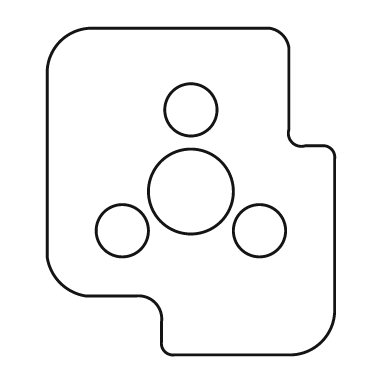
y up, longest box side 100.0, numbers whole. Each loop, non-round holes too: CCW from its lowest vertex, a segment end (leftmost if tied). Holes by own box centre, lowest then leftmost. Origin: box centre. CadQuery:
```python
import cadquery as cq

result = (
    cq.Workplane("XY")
    .moveTo(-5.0, -50.0)
    .lineTo(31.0, -50.0)
    .threePointArc((40.0, -46.0), (44.0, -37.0))
    .lineTo(44.0, 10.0)
    .threePointArc((43.0, 13.0), (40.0, 14.0))
    .lineTo(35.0, 14.0)
    .threePointArc((31.0, 15.0), (30.0, 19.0))
    .lineTo(30.0, 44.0)
    .threePointArc((28.0, 48.0), (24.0, 50.0))
    .lineTo(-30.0, 50.0)
    .threePointArc((-40.0, 46.0), (-44.0, 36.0))
    .lineTo(-44.0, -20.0)
    .threePointArc((-40.0, -28.0), (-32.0, -32.0))
    .lineTo(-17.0, -32.0)
    .threePointArc((-11.0, -34.0), (-9.0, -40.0))
    .lineTo(-9.0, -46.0)
    .threePointArc((-8.0, -49.0), (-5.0, -50.0))
    .close()
    .moveTo(-21.0, -12.0)
    .circle(8.0)
    .moveTo(21.0, -12.0)
    .circle(8.0)
    .moveTo(0.0, 0.0)
    .circle(13.0)
    .moveTo(0.0, 25.0)
    .circle(8.0)
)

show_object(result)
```